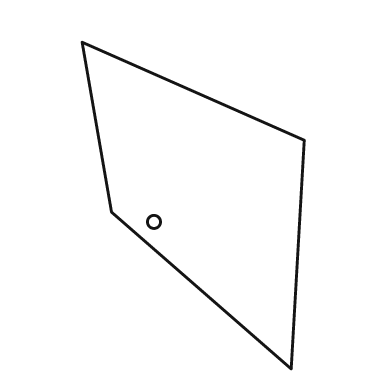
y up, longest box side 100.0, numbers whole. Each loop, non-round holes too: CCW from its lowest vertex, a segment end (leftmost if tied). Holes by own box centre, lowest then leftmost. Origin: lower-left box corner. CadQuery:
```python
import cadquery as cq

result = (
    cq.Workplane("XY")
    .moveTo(64.0, 0.0)
    .lineTo(68.0, 70.0)
    .lineTo(0.0, 100.0)
    .lineTo(9.0, 48.0)
    .close()
    .moveTo(22.0, 45.0)
    .circle(2.0)
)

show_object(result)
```